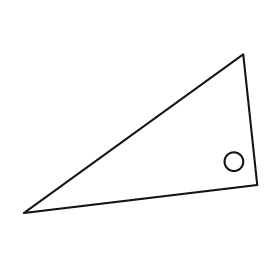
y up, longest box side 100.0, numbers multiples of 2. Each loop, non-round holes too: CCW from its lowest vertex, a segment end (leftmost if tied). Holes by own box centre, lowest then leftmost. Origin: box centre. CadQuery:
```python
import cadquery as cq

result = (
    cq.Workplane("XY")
    .moveTo(-50.0, -34.0)
    .lineTo(50.0, -22.0)
    .lineTo(44.0, 34.0)
    .close()
    .moveTo(40.0, -12.0)
    .circle(4.0)
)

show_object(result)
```